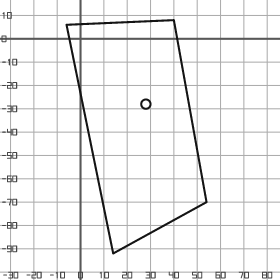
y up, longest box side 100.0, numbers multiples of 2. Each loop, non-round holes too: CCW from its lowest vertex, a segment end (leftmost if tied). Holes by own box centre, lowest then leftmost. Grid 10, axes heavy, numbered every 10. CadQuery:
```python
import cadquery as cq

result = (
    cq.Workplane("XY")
    .moveTo(14.0, -92.0)
    .lineTo(54.0, -70.0)
    .lineTo(40.0, 8.0)
    .lineTo(-6.0, 6.0)
    .close()
    .moveTo(28.0, -28.0)
    .circle(2.0)
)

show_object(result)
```